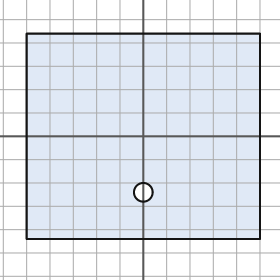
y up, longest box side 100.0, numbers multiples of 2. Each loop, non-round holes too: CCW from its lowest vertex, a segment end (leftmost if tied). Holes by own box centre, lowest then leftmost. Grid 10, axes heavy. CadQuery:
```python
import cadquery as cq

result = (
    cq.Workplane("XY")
    .moveTo(-50.0, -44.0)
    .lineTo(50.0, -44.0)
    .lineTo(50.0, 44.0)
    .lineTo(-50.0, 44.0)
    .close()
    .moveTo(0.0, -24.0)
    .circle(4.0)
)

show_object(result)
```